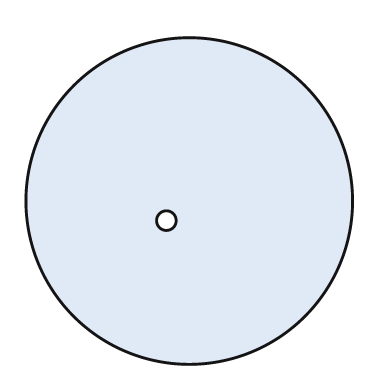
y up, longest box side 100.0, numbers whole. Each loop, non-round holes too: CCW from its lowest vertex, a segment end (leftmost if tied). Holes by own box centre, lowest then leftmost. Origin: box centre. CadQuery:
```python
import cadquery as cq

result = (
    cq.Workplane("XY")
    .moveTo(0.0, 0.0)
    .circle(50.0)
    .moveTo(-7.0, -6.0)
    .circle(3.0)
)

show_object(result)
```